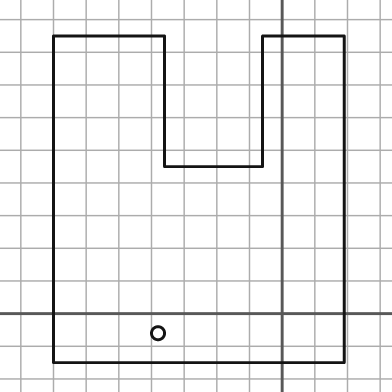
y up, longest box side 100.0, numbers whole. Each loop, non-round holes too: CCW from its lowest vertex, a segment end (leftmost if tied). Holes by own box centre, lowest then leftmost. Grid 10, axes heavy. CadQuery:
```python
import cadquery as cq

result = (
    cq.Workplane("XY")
    .moveTo(-70.0, -15.0)
    .lineTo(19.0, -15.0)
    .lineTo(19.0, 85.0)
    .lineTo(-6.0, 85.0)
    .lineTo(-6.0, 45.0)
    .lineTo(-36.0, 45.0)
    .lineTo(-36.0, 85.0)
    .lineTo(-70.0, 85.0)
    .close()
    .moveTo(-38.0, -6.0)
    .circle(2.0)
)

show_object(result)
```